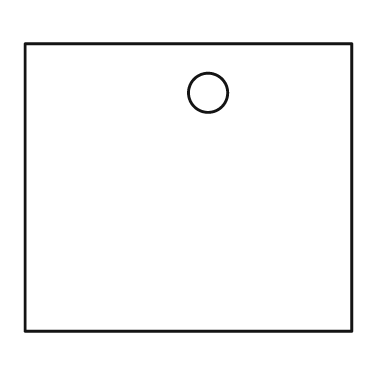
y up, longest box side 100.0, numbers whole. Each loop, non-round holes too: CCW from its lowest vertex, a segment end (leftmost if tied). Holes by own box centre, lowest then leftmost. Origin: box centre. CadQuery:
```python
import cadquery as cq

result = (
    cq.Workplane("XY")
    .moveTo(-50.0, -44.0)
    .lineTo(50.0, -44.0)
    .lineTo(50.0, 44.0)
    .lineTo(-50.0, 44.0)
    .close()
    .moveTo(6.0, 29.0)
    .circle(6.0)
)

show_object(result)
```